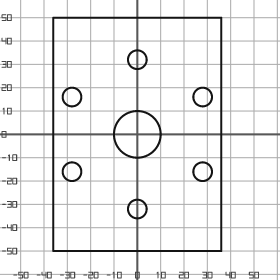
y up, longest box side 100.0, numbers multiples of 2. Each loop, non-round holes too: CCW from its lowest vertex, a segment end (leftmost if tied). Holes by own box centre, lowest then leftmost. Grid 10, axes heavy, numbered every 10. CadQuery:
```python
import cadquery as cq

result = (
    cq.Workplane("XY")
    .moveTo(-36.0, -50.0)
    .lineTo(36.0, -50.0)
    .lineTo(36.0, 50.0)
    .lineTo(-36.0, 50.0)
    .close()
    .moveTo(0.0, -32.0)
    .circle(4.0)
    .moveTo(-28.0, -16.0)
    .circle(4.0)
    .moveTo(28.0, -16.0)
    .circle(4.0)
    .moveTo(0.0, 0.0)
    .circle(10.0)
    .moveTo(-28.0, 16.0)
    .circle(4.0)
    .moveTo(28.0, 16.0)
    .circle(4.0)
    .moveTo(0.0, 32.0)
    .circle(4.0)
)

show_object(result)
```